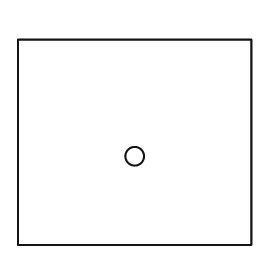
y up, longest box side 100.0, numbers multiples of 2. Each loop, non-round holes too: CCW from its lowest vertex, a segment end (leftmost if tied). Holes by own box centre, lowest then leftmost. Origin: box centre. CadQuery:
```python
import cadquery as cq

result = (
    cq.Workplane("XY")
    .moveTo(-50.0, -44.0)
    .lineTo(50.0, -44.0)
    .lineTo(50.0, 44.0)
    .lineTo(-50.0, 44.0)
    .close()
    .moveTo(0.0, -6.0)
    .circle(4.0)
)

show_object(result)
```